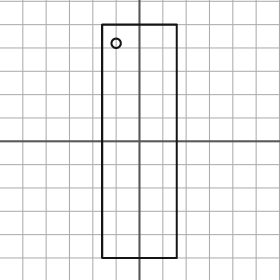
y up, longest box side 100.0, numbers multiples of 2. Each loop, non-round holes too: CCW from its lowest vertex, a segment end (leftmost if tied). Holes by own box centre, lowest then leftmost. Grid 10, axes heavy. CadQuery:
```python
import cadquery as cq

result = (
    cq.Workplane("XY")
    .moveTo(-16.0, -50.0)
    .lineTo(16.0, -50.0)
    .lineTo(16.0, 50.0)
    .lineTo(-16.0, 50.0)
    .close()
    .moveTo(-10.0, 42.0)
    .circle(2.0)
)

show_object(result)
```